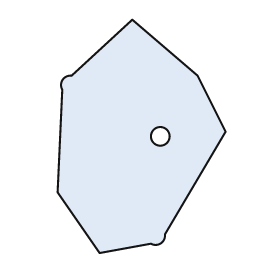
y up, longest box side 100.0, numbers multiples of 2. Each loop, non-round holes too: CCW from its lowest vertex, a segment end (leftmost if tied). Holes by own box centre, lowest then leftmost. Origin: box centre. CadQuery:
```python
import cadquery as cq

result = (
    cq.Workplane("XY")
    .moveTo(-18.0, -50.0)
    .lineTo(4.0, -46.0)
    .threePointArc((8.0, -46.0), (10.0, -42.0))
    .lineTo(36.0, 2.0)
    .lineTo(24.0, 26.0)
    .lineTo(-4.0, 50.0)
    .lineTo(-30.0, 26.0)
    .threePointArc((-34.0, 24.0), (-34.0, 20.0))
    .lineTo(-36.0, -24.0)
    .close()
    .moveTo(8.0, 0.0)
    .circle(4.0)
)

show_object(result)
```